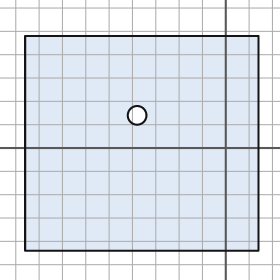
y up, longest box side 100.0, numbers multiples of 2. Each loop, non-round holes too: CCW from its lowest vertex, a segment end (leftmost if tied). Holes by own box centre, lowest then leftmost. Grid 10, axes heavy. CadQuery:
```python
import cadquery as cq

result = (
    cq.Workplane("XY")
    .moveTo(-86.0, -44.0)
    .lineTo(14.0, -44.0)
    .lineTo(14.0, 48.0)
    .lineTo(-86.0, 48.0)
    .close()
    .moveTo(-38.0, 14.0)
    .circle(4.0)
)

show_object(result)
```